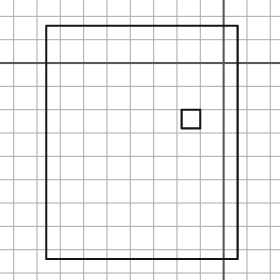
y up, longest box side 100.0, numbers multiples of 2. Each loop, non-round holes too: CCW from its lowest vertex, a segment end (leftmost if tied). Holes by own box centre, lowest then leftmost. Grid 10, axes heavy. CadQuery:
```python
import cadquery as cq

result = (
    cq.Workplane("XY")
    .moveTo(-76.0, -84.0)
    .lineTo(6.0, -84.0)
    .lineTo(6.0, 16.0)
    .lineTo(-76.0, 16.0)
    .close()
    .moveTo(-18.0, -28.0)
    .lineTo(-10.0, -28.0)
    .lineTo(-10.0, -20.0)
    .lineTo(-18.0, -20.0)
    .close()
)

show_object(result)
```